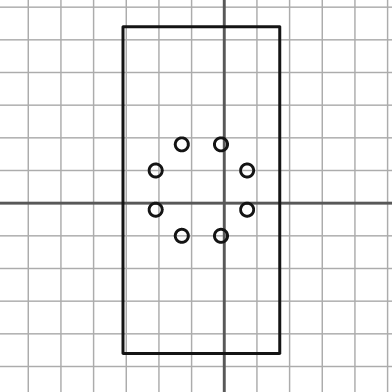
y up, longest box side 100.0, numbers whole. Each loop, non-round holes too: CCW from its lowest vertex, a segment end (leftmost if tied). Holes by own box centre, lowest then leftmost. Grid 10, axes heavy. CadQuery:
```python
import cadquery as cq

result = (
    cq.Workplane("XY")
    .moveTo(-31.0, -46.0)
    .lineTo(17.0, -46.0)
    .lineTo(17.0, 54.0)
    .lineTo(-31.0, 54.0)
    .close()
    .moveTo(-13.0, -10.0)
    .circle(2.0)
    .moveTo(-1.0, -10.0)
    .circle(2.0)
    .moveTo(-21.0, -2.0)
    .circle(2.0)
    .moveTo(7.0, -2.0)
    .circle(2.0)
    .moveTo(-21.0, 10.0)
    .circle(2.0)
    .moveTo(7.0, 10.0)
    .circle(2.0)
    .moveTo(-13.0, 18.0)
    .circle(2.0)
    .moveTo(-1.0, 18.0)
    .circle(2.0)
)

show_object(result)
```